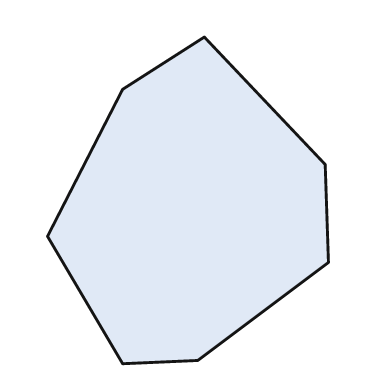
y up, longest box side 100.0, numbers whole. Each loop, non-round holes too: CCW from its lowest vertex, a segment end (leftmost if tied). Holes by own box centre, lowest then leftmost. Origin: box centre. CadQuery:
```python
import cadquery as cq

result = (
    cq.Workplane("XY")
    .moveTo(-20.0, -50.0)
    .lineTo(3.0, -49.0)
    .lineTo(43.0, -19.0)
    .lineTo(42.0, 11.0)
    .lineTo(5.0, 50.0)
    .lineTo(-20.0, 34.0)
    .lineTo(-43.0, -11.0)
    .close()
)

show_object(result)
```